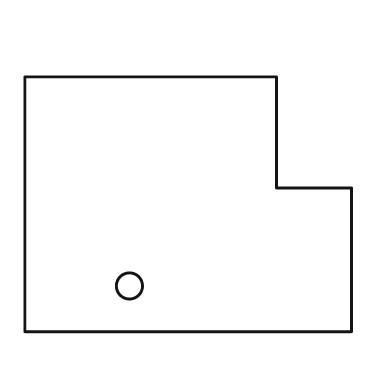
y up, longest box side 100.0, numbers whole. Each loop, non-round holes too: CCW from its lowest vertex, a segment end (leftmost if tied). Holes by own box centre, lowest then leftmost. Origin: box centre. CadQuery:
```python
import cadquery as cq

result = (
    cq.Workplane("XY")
    .moveTo(-50.0, -39.0)
    .lineTo(50.0, -39.0)
    .lineTo(50.0, 5.0)
    .lineTo(27.0, 5.0)
    .lineTo(27.0, 39.0)
    .lineTo(-50.0, 39.0)
    .close()
    .moveTo(-18.0, -25.0)
    .circle(4.0)
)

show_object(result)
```